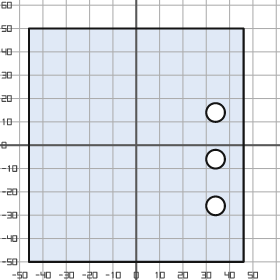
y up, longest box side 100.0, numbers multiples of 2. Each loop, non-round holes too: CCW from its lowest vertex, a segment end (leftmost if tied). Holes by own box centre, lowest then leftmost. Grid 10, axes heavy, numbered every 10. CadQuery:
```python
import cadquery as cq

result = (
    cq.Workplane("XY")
    .moveTo(-46.0, -50.0)
    .lineTo(46.0, -50.0)
    .lineTo(46.0, 50.0)
    .lineTo(-46.0, 50.0)
    .close()
    .moveTo(34.0, -26.0)
    .circle(4.0)
    .moveTo(34.0, -6.0)
    .circle(4.0)
    .moveTo(34.0, 14.0)
    .circle(4.0)
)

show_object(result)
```